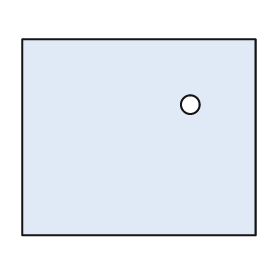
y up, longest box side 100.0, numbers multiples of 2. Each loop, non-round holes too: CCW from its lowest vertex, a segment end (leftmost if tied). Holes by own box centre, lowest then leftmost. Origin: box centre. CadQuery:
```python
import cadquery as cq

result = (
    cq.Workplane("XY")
    .moveTo(-50.0, -42.0)
    .lineTo(50.0, -42.0)
    .lineTo(50.0, 42.0)
    .lineTo(-50.0, 42.0)
    .close()
    .moveTo(22.0, 14.0)
    .circle(4.0)
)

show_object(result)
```